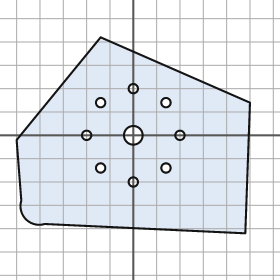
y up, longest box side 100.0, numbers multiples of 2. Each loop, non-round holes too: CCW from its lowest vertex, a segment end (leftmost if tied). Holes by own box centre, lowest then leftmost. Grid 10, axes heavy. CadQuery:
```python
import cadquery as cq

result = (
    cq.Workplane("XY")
    .moveTo(48.0, -42.0)
    .lineTo(50.0, 14.0)
    .lineTo(-14.0, 42.0)
    .lineTo(-50.0, -2.0)
    .lineTo(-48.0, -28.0)
    .threePointArc((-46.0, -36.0), (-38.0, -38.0))
    .close()
    .moveTo(0.0, -20.0)
    .circle(2.0)
    .moveTo(-14.0, -14.0)
    .circle(2.0)
    .moveTo(14.0, -14.0)
    .circle(2.0)
    .moveTo(-20.0, 0.0)
    .circle(2.0)
    .moveTo(0.0, 0.0)
    .circle(4.0)
    .moveTo(20.0, 0.0)
    .circle(2.0)
    .moveTo(-14.0, 14.0)
    .circle(2.0)
    .moveTo(14.0, 14.0)
    .circle(2.0)
    .moveTo(0.0, 20.0)
    .circle(2.0)
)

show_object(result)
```